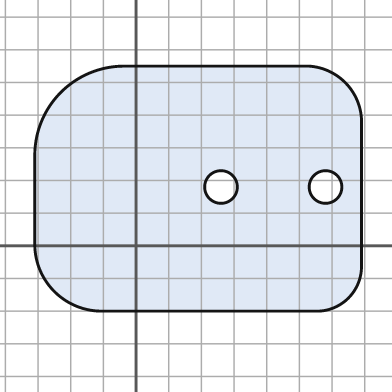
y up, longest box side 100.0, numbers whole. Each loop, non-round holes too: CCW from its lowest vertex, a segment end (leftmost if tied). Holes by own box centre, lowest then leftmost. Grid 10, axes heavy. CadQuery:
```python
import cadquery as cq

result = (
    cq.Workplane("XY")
    .moveTo(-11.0, -20.0)
    .lineTo(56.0, -20.0)
    .threePointArc((65.0, -16.0), (69.0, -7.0))
    .lineTo(69.0, 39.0)
    .threePointArc((64.0, 50.0), (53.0, 55.0))
    .lineTo(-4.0, 55.0)
    .threePointArc((-23.0, 47.0), (-31.0, 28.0))
    .lineTo(-31.0, 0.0)
    .threePointArc((-25.0, -14.0), (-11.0, -20.0))
    .close()
    .moveTo(26.0, 18.0)
    .circle(5.0)
    .moveTo(58.0, 18.0)
    .circle(5.0)
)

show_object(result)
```